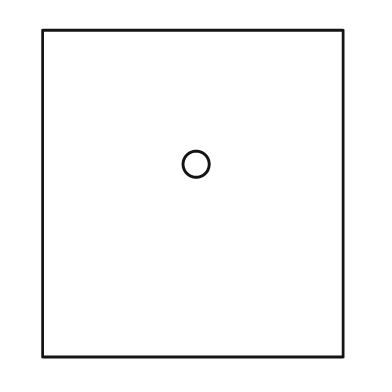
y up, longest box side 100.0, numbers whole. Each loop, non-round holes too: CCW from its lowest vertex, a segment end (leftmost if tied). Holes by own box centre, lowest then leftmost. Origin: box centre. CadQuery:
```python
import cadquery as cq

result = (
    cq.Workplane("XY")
    .moveTo(-46.0, -50.0)
    .lineTo(46.0, -50.0)
    .lineTo(46.0, 50.0)
    .lineTo(-46.0, 50.0)
    .close()
    .moveTo(1.0, 9.0)
    .circle(4.0)
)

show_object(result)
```